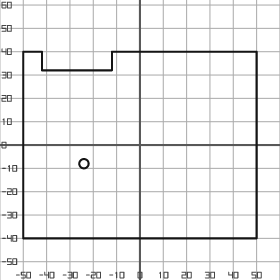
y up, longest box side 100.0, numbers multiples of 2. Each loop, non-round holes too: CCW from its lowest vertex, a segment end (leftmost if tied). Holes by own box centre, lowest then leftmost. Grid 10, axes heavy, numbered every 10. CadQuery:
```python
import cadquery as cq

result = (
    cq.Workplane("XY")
    .moveTo(-50.0, -40.0)
    .lineTo(50.0, -40.0)
    .lineTo(50.0, 40.0)
    .lineTo(-12.0, 40.0)
    .lineTo(-12.0, 32.0)
    .lineTo(-42.0, 32.0)
    .lineTo(-42.0, 40.0)
    .lineTo(-50.0, 40.0)
    .close()
    .moveTo(-24.0, -8.0)
    .circle(2.0)
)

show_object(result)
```